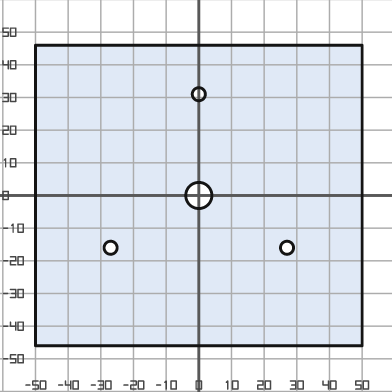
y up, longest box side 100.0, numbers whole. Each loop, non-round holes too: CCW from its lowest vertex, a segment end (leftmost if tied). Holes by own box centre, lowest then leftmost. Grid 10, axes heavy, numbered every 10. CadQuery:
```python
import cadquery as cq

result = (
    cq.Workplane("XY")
    .moveTo(-50.0, -46.0)
    .lineTo(50.0, -46.0)
    .lineTo(50.0, 46.0)
    .lineTo(-50.0, 46.0)
    .close()
    .moveTo(-27.0, -16.0)
    .circle(2.0)
    .moveTo(27.0, -16.0)
    .circle(2.0)
    .moveTo(0.0, 0.0)
    .circle(4.0)
    .moveTo(0.0, 31.0)
    .circle(2.0)
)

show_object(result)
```